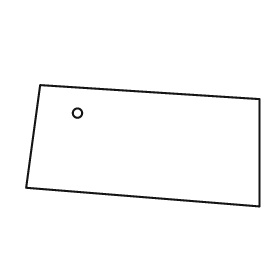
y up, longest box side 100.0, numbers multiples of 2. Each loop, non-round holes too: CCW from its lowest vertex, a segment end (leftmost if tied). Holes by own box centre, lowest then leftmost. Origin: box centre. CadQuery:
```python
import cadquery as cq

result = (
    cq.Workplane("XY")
    .moveTo(50.0, -26.0)
    .lineTo(50.0, 20.0)
    .lineTo(-44.0, 26.0)
    .lineTo(-50.0, -18.0)
    .close()
    .moveTo(-28.0, 14.0)
    .circle(2.0)
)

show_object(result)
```